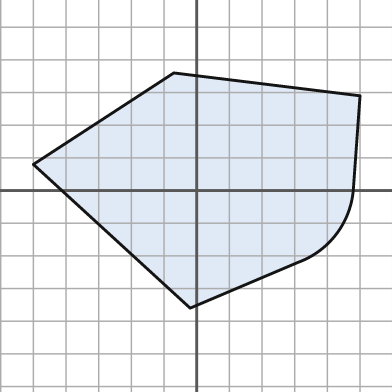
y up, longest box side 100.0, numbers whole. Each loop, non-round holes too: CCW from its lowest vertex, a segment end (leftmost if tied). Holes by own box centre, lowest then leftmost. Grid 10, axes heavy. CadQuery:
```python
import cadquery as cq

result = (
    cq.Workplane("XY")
    .moveTo(-2.0, -36.0)
    .lineTo(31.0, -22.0)
    .threePointArc((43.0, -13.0), (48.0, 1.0))
    .lineTo(50.0, 29.0)
    .lineTo(-7.0, 36.0)
    .lineTo(-50.0, 8.0)
    .close()
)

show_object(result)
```